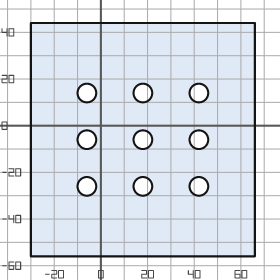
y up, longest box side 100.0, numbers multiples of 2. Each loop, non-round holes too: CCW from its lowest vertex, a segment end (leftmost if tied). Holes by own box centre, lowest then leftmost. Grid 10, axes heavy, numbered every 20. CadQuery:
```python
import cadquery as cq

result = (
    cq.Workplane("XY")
    .moveTo(-30.0, -56.0)
    .lineTo(66.0, -56.0)
    .lineTo(66.0, 44.0)
    .lineTo(-30.0, 44.0)
    .close()
    .moveTo(-6.0, -26.0)
    .circle(4.0)
    .moveTo(18.0, -26.0)
    .circle(4.0)
    .moveTo(42.0, -26.0)
    .circle(4.0)
    .moveTo(-6.0, -6.0)
    .circle(4.0)
    .moveTo(18.0, -6.0)
    .circle(4.0)
    .moveTo(42.0, -6.0)
    .circle(4.0)
    .moveTo(-6.0, 14.0)
    .circle(4.0)
    .moveTo(18.0, 14.0)
    .circle(4.0)
    .moveTo(42.0, 14.0)
    .circle(4.0)
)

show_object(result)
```